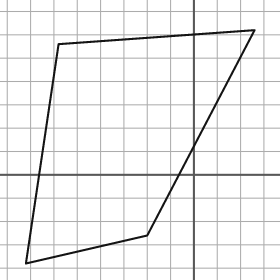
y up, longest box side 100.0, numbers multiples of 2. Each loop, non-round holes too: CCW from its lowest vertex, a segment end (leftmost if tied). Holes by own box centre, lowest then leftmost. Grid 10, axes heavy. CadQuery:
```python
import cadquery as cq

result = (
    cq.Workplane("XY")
    .moveTo(-72.0, -38.0)
    .lineTo(-20.0, -26.0)
    .lineTo(26.0, 62.0)
    .lineTo(-58.0, 56.0)
    .close()
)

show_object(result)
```